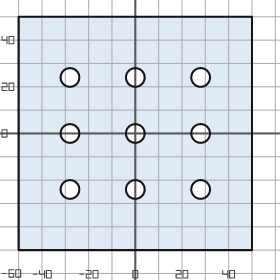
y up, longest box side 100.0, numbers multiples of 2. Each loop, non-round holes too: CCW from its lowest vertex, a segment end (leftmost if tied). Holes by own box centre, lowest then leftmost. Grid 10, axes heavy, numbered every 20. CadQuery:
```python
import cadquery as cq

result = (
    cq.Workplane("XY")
    .moveTo(-50.0, -50.0)
    .lineTo(50.0, -50.0)
    .lineTo(50.0, 50.0)
    .lineTo(-50.0, 50.0)
    .close()
    .moveTo(-28.0, -24.0)
    .circle(4.0)
    .moveTo(0.0, -24.0)
    .circle(4.0)
    .moveTo(28.0, -24.0)
    .circle(4.0)
    .moveTo(-28.0, 0.0)
    .circle(4.0)
    .moveTo(0.0, 0.0)
    .circle(4.0)
    .moveTo(28.0, 0.0)
    .circle(4.0)
    .moveTo(-28.0, 24.0)
    .circle(4.0)
    .moveTo(0.0, 24.0)
    .circle(4.0)
    .moveTo(28.0, 24.0)
    .circle(4.0)
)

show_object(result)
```